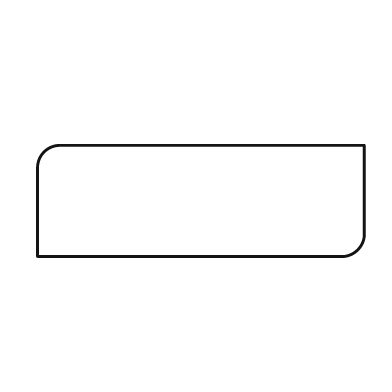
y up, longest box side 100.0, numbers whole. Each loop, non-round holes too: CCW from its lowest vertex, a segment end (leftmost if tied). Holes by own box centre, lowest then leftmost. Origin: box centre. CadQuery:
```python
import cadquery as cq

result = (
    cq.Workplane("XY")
    .moveTo(-50.0, -17.0)
    .lineTo(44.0, -17.0)
    .threePointArc((48.0, -15.0), (50.0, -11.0))
    .lineTo(50.0, 17.0)
    .lineTo(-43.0, 17.0)
    .threePointArc((-48.0, 15.0), (-50.0, 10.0))
    .close()
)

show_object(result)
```